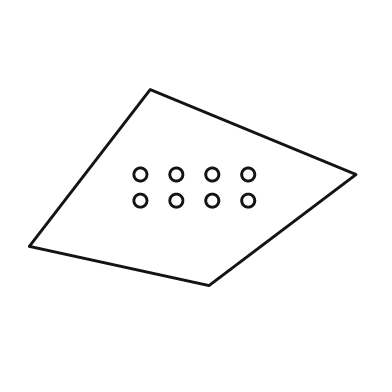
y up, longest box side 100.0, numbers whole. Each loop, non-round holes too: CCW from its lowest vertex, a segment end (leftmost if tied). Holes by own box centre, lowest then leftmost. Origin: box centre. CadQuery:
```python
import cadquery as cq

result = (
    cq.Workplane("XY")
    .moveTo(5.0, -30.0)
    .lineTo(50.0, 4.0)
    .lineTo(-13.0, 30.0)
    .lineTo(-50.0, -18.0)
    .close()
    .moveTo(-16.0, -4.0)
    .circle(2.0)
    .moveTo(-5.0, -4.0)
    .circle(2.0)
    .moveTo(6.0, -4.0)
    .circle(2.0)
    .moveTo(17.0, -4.0)
    .circle(2.0)
    .moveTo(-16.0, 4.0)
    .circle(2.0)
    .moveTo(-5.0, 4.0)
    .circle(2.0)
    .moveTo(6.0, 4.0)
    .circle(2.0)
    .moveTo(17.0, 4.0)
    .circle(2.0)
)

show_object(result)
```